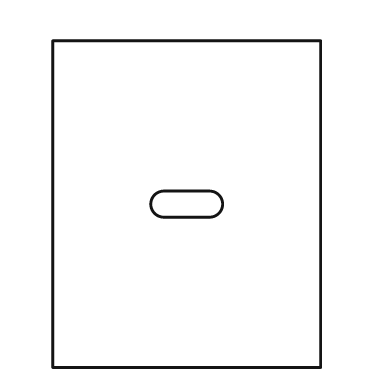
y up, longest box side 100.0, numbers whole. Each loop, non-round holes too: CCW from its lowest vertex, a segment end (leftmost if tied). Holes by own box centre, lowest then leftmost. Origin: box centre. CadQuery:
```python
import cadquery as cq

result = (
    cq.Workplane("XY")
    .moveTo(-41.0, -50.0)
    .lineTo(41.0, -50.0)
    .lineTo(41.0, 50.0)
    .lineTo(-41.0, 50.0)
    .close()
    .moveTo(-7.0, -4.0)
    .lineTo(7.0, -4.0)
    .threePointArc((11.0, 0.0), (7.0, 4.0))
    .lineTo(-7.0, 4.0)
    .threePointArc((-11.0, 0.0), (-7.0, -4.0))
    .close()
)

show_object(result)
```